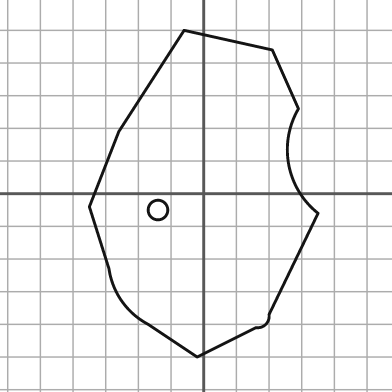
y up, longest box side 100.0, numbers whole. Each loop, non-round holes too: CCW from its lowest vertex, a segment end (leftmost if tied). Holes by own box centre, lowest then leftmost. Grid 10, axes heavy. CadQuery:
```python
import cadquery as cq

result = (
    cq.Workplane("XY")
    .moveTo(-2.0, -50.0)
    .lineTo(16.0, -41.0)
    .threePointArc((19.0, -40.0), (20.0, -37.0))
    .lineTo(35.0, -6.0)
    .threePointArc((26.0, 9.0), (29.0, 26.0))
    .lineTo(21.0, 44.0)
    .lineTo(-6.0, 50.0)
    .lineTo(-26.0, 19.0)
    .lineTo(-35.0, -4.0)
    .lineTo(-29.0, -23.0)
    .threePointArc((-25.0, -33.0), (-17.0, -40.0))
    .close()
    .moveTo(-14.0, -5.0)
    .circle(3.0)
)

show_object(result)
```